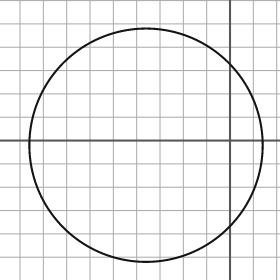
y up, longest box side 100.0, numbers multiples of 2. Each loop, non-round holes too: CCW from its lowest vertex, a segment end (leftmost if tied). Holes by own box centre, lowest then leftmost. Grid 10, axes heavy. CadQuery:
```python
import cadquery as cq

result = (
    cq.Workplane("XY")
    .moveTo(-36.0, -2.0)
    .circle(50.0)
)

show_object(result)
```